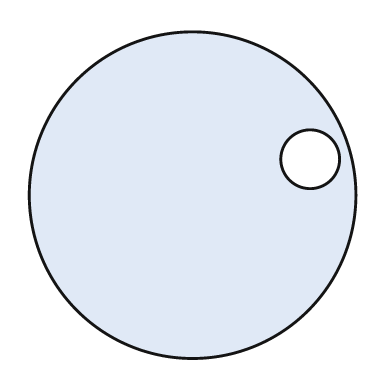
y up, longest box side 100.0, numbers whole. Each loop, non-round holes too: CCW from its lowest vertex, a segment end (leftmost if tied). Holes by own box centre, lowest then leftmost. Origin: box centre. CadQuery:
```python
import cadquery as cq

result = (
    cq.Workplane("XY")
    .moveTo(0.0, 0.0)
    .circle(50.0)
    .moveTo(36.0, 11.0)
    .circle(9.0)
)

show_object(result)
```